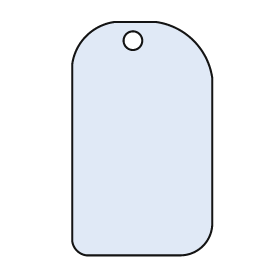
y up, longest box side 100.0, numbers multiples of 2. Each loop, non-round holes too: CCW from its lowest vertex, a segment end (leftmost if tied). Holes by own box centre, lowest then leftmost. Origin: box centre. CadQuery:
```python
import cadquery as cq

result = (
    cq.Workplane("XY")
    .moveTo(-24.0, -50.0)
    .lineTo(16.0, -50.0)
    .threePointArc((26.0, -46.0), (30.0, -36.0))
    .lineTo(30.0, 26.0)
    .threePointArc((22.0, 42.0), (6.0, 50.0))
    .lineTo(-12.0, 50.0)
    .threePointArc((-24.0, 44.0), (-30.0, 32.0))
    .lineTo(-30.0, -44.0)
    .threePointArc((-28.0, -48.0), (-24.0, -50.0))
    .close()
    .moveTo(-4.0, 42.0)
    .circle(4.0)
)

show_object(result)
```